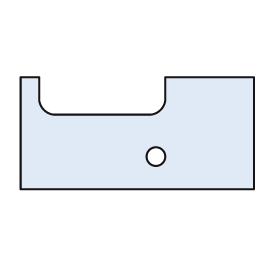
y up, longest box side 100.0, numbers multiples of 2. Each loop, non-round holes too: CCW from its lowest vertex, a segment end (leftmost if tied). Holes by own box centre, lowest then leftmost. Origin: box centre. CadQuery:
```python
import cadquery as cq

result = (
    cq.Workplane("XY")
    .moveTo(-50.0, -24.0)
    .lineTo(50.0, -24.0)
    .lineTo(50.0, 24.0)
    .lineTo(12.0, 24.0)
    .lineTo(12.0, 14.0)
    .threePointArc((10.0, 10.0), (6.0, 8.0))
    .lineTo(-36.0, 8.0)
    .threePointArc((-40.0, 10.0), (-42.0, 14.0))
    .lineTo(-42.0, 24.0)
    .lineTo(-50.0, 24.0)
    .close()
    .moveTo(8.0, -10.0)
    .circle(4.0)
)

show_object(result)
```